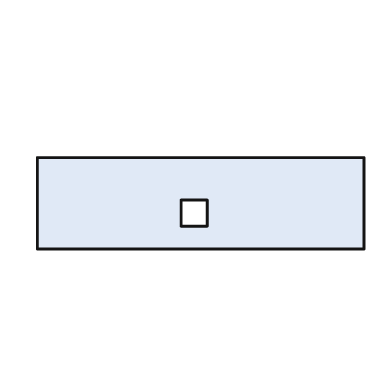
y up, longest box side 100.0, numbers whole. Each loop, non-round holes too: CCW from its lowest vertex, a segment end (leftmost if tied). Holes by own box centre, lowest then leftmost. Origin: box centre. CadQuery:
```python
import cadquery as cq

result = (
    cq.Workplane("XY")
    .moveTo(-50.0, -14.0)
    .lineTo(50.0, -14.0)
    .lineTo(50.0, 14.0)
    .lineTo(-50.0, 14.0)
    .close()
    .moveTo(-6.0, -7.0)
    .lineTo(2.0, -7.0)
    .lineTo(2.0, 1.0)
    .lineTo(-6.0, 1.0)
    .close()
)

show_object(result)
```